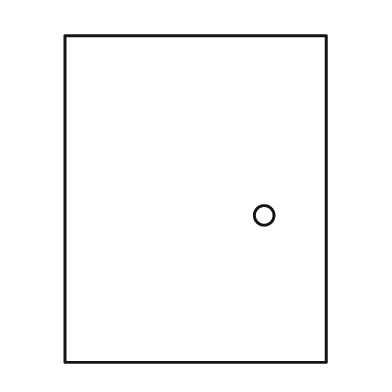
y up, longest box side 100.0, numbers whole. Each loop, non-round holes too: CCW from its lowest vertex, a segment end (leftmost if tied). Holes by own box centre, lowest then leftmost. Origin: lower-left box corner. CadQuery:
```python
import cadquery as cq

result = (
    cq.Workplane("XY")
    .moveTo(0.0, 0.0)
    .lineTo(80.0, 0.0)
    .lineTo(80.0, 100.0)
    .lineTo(0.0, 100.0)
    .close()
    .moveTo(61.0, 45.0)
    .circle(3.0)
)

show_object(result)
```